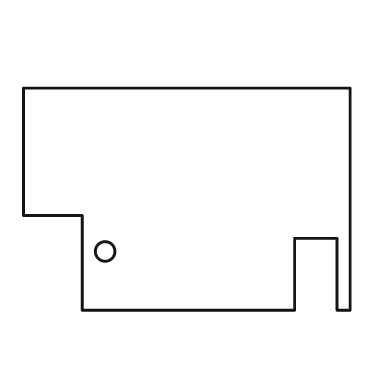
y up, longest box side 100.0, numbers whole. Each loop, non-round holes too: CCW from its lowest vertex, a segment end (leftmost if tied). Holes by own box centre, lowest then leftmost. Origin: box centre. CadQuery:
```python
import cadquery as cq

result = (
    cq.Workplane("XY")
    .moveTo(-32.0, -34.0)
    .lineTo(33.0, -34.0)
    .lineTo(33.0, -12.0)
    .lineTo(46.0, -12.0)
    .lineTo(46.0, -34.0)
    .lineTo(50.0, -34.0)
    .lineTo(50.0, 34.0)
    .lineTo(-50.0, 34.0)
    .lineTo(-50.0, -5.0)
    .lineTo(-32.0, -5.0)
    .close()
    .moveTo(-25.0, -16.0)
    .circle(3.0)
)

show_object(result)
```